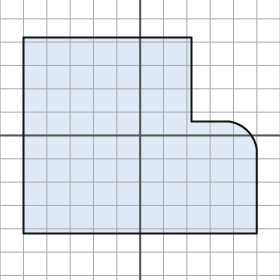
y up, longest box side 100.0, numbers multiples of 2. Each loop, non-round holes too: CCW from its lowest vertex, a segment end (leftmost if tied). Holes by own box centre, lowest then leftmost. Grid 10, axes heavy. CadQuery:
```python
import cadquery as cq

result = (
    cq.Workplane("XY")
    .moveTo(-50.0, -42.0)
    .lineTo(50.0, -42.0)
    .lineTo(50.0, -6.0)
    .threePointArc((46.0, 2.0), (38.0, 6.0))
    .lineTo(22.0, 6.0)
    .lineTo(22.0, 42.0)
    .lineTo(-50.0, 42.0)
    .close()
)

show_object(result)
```